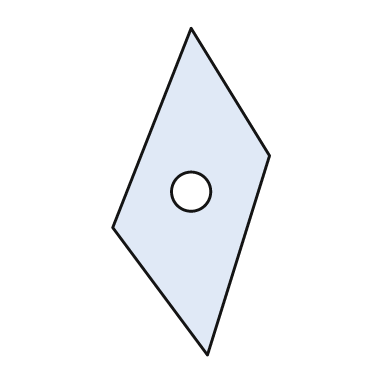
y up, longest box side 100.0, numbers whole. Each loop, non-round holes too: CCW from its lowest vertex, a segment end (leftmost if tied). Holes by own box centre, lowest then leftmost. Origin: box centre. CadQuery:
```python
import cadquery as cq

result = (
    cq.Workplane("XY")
    .moveTo(5.0, -50.0)
    .lineTo(24.0, 11.0)
    .lineTo(0.0, 50.0)
    .lineTo(-24.0, -11.0)
    .close()
    .moveTo(0.0, 0.0)
    .circle(6.0)
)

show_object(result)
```